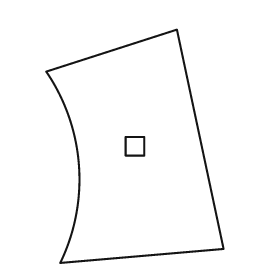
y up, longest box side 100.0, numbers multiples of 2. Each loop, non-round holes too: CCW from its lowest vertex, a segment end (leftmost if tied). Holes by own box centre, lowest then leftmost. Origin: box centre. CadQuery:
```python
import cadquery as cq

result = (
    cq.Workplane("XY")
    .moveTo(-32.0, -50.0)
    .lineTo(38.0, -44.0)
    .lineTo(18.0, 50.0)
    .lineTo(-38.0, 32.0)
    .threePointArc((-24.0, -8.0), (-32.0, -50.0))
    .close()
    .moveTo(-4.0, -4.0)
    .lineTo(4.0, -4.0)
    .lineTo(4.0, 4.0)
    .lineTo(-4.0, 4.0)
    .close()
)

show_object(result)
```